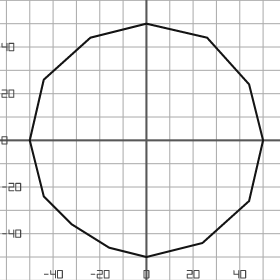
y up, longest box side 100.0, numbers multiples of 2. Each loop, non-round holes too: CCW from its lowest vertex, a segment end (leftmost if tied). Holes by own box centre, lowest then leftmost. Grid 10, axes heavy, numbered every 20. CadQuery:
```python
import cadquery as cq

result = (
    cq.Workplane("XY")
    .moveTo(0.0, -50.0)
    .lineTo(24.0, -44.0)
    .lineTo(44.0, -26.0)
    .lineTo(50.0, 0.0)
    .lineTo(44.0, 24.0)
    .lineTo(26.0, 44.0)
    .lineTo(0.0, 50.0)
    .lineTo(-24.0, 44.0)
    .lineTo(-44.0, 26.0)
    .lineTo(-50.0, 0.0)
    .lineTo(-44.0, -24.0)
    .lineTo(-32.0, -36.0)
    .lineTo(-16.0, -46.0)
    .close()
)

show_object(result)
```